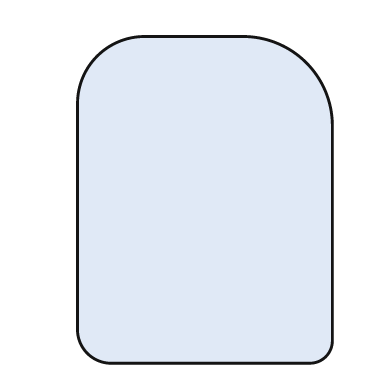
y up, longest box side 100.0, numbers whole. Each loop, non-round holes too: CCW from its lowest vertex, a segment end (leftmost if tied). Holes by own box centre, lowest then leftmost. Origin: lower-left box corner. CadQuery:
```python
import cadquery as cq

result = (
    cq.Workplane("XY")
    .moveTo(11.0, 0.0)
    .lineTo(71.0, 0.0)
    .threePointArc((76.0, 2.0), (78.0, 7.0))
    .lineTo(78.0, 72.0)
    .threePointArc((70.0, 92.0), (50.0, 100.0))
    .lineTo(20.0, 100.0)
    .threePointArc((6.0, 94.0), (0.0, 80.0))
    .lineTo(0.0, 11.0)
    .threePointArc((3.0, 3.0), (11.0, 0.0))
    .close()
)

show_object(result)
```